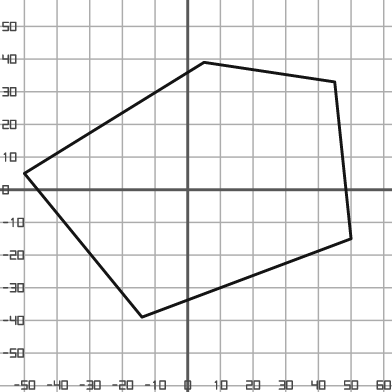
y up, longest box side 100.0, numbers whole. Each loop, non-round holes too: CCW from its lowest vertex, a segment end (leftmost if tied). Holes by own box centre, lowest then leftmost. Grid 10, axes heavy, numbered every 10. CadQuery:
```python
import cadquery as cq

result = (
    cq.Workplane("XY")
    .moveTo(-14.0, -39.0)
    .lineTo(50.0, -15.0)
    .lineTo(45.0, 33.0)
    .lineTo(5.0, 39.0)
    .lineTo(-50.0, 5.0)
    .close()
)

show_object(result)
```